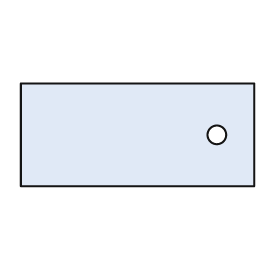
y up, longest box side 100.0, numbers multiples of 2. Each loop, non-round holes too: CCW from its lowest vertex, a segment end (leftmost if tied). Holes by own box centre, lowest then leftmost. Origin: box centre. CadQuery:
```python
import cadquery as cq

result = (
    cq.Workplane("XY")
    .moveTo(-50.0, -22.0)
    .lineTo(50.0, -22.0)
    .lineTo(50.0, 22.0)
    .lineTo(-50.0, 22.0)
    .close()
    .moveTo(34.0, 0.0)
    .circle(4.0)
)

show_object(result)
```